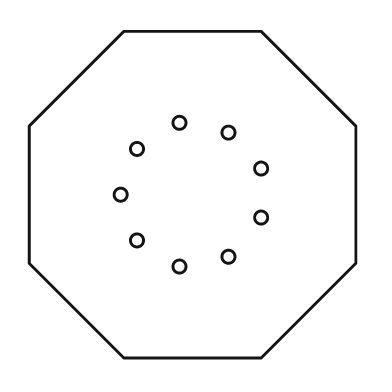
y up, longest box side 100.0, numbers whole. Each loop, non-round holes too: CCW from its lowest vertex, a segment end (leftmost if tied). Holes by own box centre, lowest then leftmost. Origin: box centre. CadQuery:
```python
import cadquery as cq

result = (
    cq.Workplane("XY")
    .moveTo(-21.0, -50.0)
    .lineTo(21.0, -50.0)
    .lineTo(50.0, -21.0)
    .lineTo(50.0, 21.0)
    .lineTo(21.0, 50.0)
    .lineTo(-21.0, 50.0)
    .lineTo(-50.0, 21.0)
    .lineTo(-50.0, -21.0)
    .close()
    .moveTo(-4.0, -22.0)
    .circle(2.0)
    .moveTo(11.0, -19.0)
    .circle(2.0)
    .moveTo(-17.0, -14.0)
    .circle(2.0)
    .moveTo(21.0, -7.0)
    .circle(2.0)
    .moveTo(-22.0, 0.0)
    .circle(2.0)
    .moveTo(21.0, 8.0)
    .circle(2.0)
    .moveTo(-17.0, 14.0)
    .circle(2.0)
    .moveTo(11.0, 19.0)
    .circle(2.0)
    .moveTo(-4.0, 22.0)
    .circle(2.0)
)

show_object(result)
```